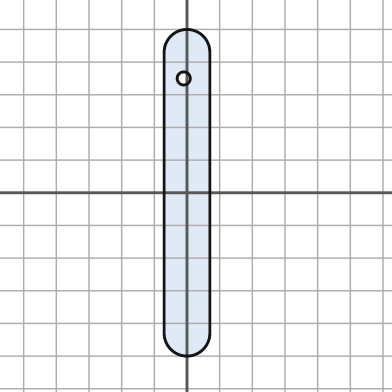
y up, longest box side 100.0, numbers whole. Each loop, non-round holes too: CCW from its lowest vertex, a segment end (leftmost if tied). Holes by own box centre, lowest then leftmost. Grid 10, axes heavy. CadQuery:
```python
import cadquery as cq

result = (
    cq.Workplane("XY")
    .moveTo(-7.0, -43.0)
    .threePointArc((0.0, -50.0), (7.0, -43.0))
    .lineTo(7.0, 43.0)
    .threePointArc((0.0, 50.0), (-7.0, 43.0))
    .close()
    .moveTo(-1.0, 35.0)
    .circle(2.0)
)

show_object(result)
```